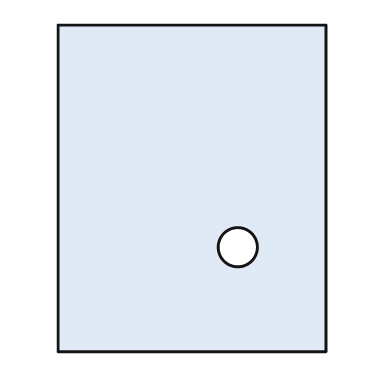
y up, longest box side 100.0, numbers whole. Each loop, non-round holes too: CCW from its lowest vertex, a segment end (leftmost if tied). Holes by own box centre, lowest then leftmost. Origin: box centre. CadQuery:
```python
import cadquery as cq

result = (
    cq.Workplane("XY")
    .moveTo(-41.0, -50.0)
    .lineTo(41.0, -50.0)
    .lineTo(41.0, 50.0)
    .lineTo(-41.0, 50.0)
    .close()
    .moveTo(14.0, -18.0)
    .circle(6.0)
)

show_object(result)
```